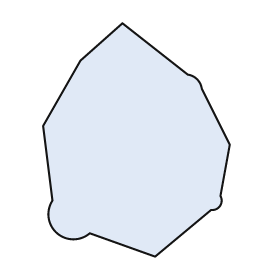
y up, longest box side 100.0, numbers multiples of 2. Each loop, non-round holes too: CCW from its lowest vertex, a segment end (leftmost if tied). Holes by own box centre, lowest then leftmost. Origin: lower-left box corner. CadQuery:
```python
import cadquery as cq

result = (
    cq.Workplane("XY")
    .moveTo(48.0, 0.0)
    .lineTo(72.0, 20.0)
    .threePointArc((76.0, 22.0), (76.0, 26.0))
    .lineTo(80.0, 48.0)
    .lineTo(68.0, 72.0)
    .threePointArc((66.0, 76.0), (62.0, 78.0))
    .lineTo(34.0, 100.0)
    .lineTo(16.0, 84.0)
    .lineTo(0.0, 56.0)
    .lineTo(4.0, 24.0)
    .threePointArc((6.0, 10.0), (20.0, 10.0))
    .close()
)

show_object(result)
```